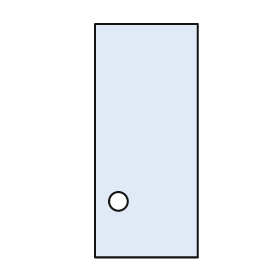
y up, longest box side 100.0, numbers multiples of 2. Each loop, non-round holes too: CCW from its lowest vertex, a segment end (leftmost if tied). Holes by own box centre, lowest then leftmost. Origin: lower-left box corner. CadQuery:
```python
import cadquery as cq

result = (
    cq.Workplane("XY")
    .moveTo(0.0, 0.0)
    .lineTo(44.0, 0.0)
    .lineTo(44.0, 100.0)
    .lineTo(0.0, 100.0)
    .close()
    .moveTo(10.0, 24.0)
    .circle(4.0)
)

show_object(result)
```